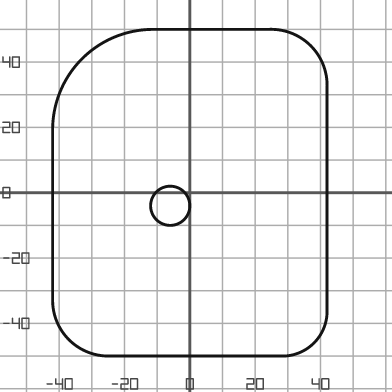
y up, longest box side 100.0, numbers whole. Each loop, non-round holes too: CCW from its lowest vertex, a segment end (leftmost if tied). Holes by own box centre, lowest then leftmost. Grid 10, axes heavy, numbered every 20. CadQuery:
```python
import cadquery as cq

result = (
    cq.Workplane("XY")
    .moveTo(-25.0, -50.0)
    .lineTo(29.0, -50.0)
    .threePointArc((38.0, -46.0), (42.0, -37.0))
    .lineTo(42.0, 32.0)
    .threePointArc((37.0, 45.0), (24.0, 50.0))
    .lineTo(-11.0, 50.0)
    .threePointArc((-33.0, 41.0), (-42.0, 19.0))
    .lineTo(-42.0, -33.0)
    .threePointArc((-37.0, -45.0), (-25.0, -50.0))
    .close()
    .moveTo(-6.0, -4.0)
    .circle(6.0)
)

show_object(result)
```